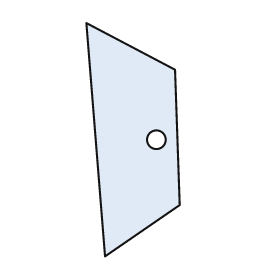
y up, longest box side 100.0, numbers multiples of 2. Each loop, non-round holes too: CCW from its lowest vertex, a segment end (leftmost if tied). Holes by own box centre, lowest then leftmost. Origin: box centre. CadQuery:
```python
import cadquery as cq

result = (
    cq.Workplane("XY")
    .moveTo(-12.0, -50.0)
    .lineTo(20.0, -28.0)
    .lineTo(18.0, 30.0)
    .lineTo(-20.0, 50.0)
    .close()
    .moveTo(10.0, 0.0)
    .circle(4.0)
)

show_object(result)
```